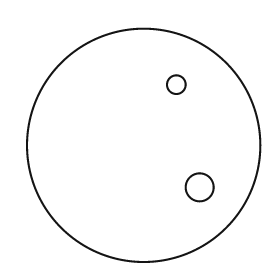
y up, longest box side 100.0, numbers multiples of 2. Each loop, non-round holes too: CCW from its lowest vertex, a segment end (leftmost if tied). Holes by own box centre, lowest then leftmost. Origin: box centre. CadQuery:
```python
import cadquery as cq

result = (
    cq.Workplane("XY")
    .moveTo(0.0, 0.0)
    .circle(50.0)
    .moveTo(24.0, -18.0)
    .circle(6.0)
    .moveTo(14.0, 26.0)
    .circle(4.0)
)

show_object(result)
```